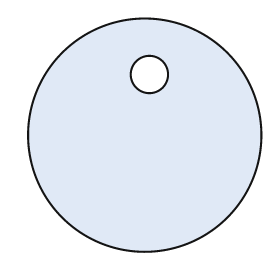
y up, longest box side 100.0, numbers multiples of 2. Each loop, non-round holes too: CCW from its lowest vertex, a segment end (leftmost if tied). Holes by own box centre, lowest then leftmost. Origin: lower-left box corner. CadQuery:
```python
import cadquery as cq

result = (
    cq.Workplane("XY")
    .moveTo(50.0, 50.0)
    .circle(50.0)
    .moveTo(52.0, 76.0)
    .circle(8.0)
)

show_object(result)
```